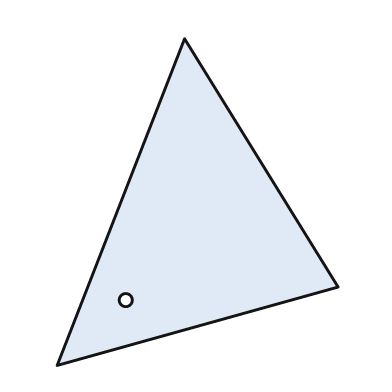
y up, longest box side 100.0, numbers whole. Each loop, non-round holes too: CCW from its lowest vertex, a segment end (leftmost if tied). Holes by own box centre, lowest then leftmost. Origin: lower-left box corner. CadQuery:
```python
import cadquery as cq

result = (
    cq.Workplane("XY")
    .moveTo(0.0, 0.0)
    .lineTo(86.0, 24.0)
    .lineTo(39.0, 100.0)
    .close()
    .moveTo(21.0, 20.0)
    .circle(2.0)
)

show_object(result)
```